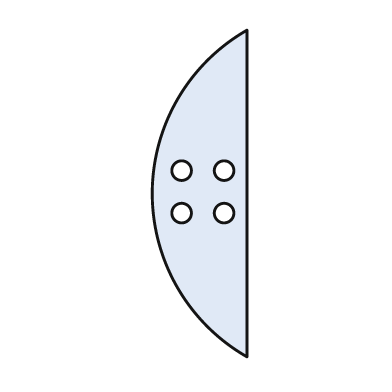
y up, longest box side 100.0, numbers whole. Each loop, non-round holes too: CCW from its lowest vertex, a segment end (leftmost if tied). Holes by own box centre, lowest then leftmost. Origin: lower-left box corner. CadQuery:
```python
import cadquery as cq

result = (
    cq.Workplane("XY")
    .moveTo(29.0, 0.0)
    .lineTo(29.0, 100.0)
    .threePointArc((0.0, 50.0), (29.0, 0.0))
    .close()
    .moveTo(9.0, 44.0)
    .circle(3.0)
    .moveTo(22.0, 44.0)
    .circle(3.0)
    .moveTo(9.0, 57.0)
    .circle(3.0)
    .moveTo(22.0, 57.0)
    .circle(3.0)
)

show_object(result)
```